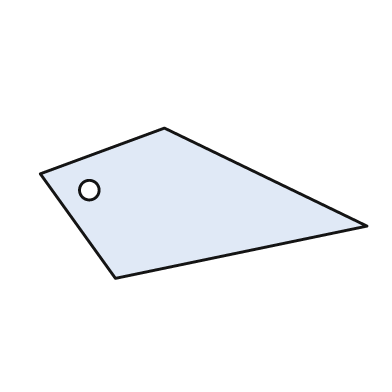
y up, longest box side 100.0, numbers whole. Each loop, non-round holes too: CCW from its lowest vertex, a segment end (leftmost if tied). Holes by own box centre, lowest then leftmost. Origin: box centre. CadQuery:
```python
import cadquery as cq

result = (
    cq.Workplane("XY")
    .moveTo(-27.0, -23.0)
    .lineTo(50.0, -7.0)
    .lineTo(-12.0, 23.0)
    .lineTo(-50.0, 9.0)
    .close()
    .moveTo(-35.0, 4.0)
    .circle(3.0)
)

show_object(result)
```